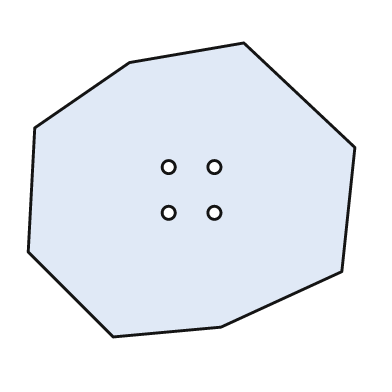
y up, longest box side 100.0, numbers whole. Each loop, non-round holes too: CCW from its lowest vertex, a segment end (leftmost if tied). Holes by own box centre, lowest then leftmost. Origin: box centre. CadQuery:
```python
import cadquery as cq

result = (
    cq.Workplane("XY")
    .moveTo(-24.0, -45.0)
    .lineTo(9.0, -42.0)
    .lineTo(46.0, -25.0)
    .lineTo(50.0, 13.0)
    .lineTo(16.0, 45.0)
    .lineTo(-19.0, 39.0)
    .lineTo(-48.0, 19.0)
    .lineTo(-50.0, -19.0)
    .close()
    .moveTo(-7.0, -7.0)
    .circle(2.0)
    .moveTo(7.0, -7.0)
    .circle(2.0)
    .moveTo(-7.0, 7.0)
    .circle(2.0)
    .moveTo(7.0, 7.0)
    .circle(2.0)
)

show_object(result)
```